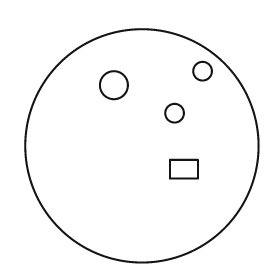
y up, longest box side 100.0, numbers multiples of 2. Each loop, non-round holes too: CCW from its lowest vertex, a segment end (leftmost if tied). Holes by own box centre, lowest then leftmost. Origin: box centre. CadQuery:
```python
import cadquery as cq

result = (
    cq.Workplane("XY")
    .moveTo(0.0, 0.0)
    .circle(50.0)
    .moveTo(12.0, -14.0)
    .lineTo(24.0, -14.0)
    .lineTo(24.0, -6.0)
    .lineTo(12.0, -6.0)
    .close()
    .moveTo(14.0, 14.0)
    .circle(4.0)
    .moveTo(-12.0, 26.0)
    .circle(6.0)
    .moveTo(26.0, 32.0)
    .circle(4.0)
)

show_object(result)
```